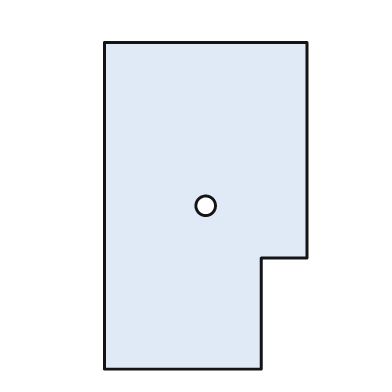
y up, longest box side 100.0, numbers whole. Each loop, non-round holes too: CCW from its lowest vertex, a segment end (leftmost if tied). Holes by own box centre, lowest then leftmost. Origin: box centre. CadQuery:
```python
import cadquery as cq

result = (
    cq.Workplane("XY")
    .moveTo(-31.0, -50.0)
    .lineTo(17.0, -50.0)
    .lineTo(17.0, -16.0)
    .lineTo(31.0, -16.0)
    .lineTo(31.0, 50.0)
    .lineTo(-31.0, 50.0)
    .close()
    .moveTo(0.0, 0.0)
    .circle(3.0)
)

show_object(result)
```